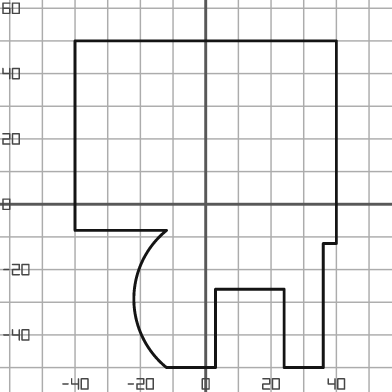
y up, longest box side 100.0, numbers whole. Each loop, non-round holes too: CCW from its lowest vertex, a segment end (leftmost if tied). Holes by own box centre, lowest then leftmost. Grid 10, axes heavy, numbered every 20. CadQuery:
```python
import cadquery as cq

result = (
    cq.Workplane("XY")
    .moveTo(-12.0, -50.0)
    .lineTo(3.0, -50.0)
    .lineTo(3.0, -26.0)
    .lineTo(24.0, -26.0)
    .lineTo(24.0, -50.0)
    .lineTo(36.0, -50.0)
    .lineTo(36.0, -12.0)
    .lineTo(40.0, -12.0)
    .lineTo(40.0, 50.0)
    .lineTo(-40.0, 50.0)
    .lineTo(-40.0, -8.0)
    .lineTo(-12.0, -8.0)
    .threePointArc((-22.0, -29.0), (-12.0, -50.0))
    .close()
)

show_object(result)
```